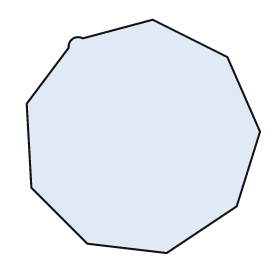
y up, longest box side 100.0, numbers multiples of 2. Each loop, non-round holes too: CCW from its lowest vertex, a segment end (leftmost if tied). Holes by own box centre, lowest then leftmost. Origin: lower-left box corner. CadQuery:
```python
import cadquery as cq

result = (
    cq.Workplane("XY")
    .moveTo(60.0, 0.0)
    .lineTo(90.0, 20.0)
    .lineTo(100.0, 52.0)
    .lineTo(86.0, 84.0)
    .lineTo(54.0, 100.0)
    .lineTo(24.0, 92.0)
    .threePointArc((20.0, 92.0), (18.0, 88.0))
    .lineTo(0.0, 64.0)
    .lineTo(2.0, 28.0)
    .lineTo(26.0, 4.0)
    .close()
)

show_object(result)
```